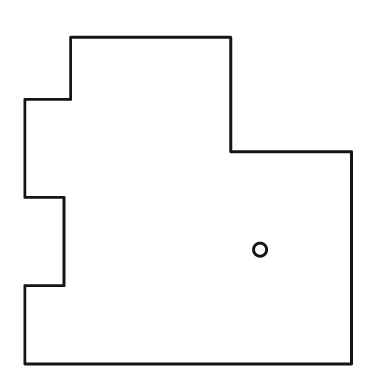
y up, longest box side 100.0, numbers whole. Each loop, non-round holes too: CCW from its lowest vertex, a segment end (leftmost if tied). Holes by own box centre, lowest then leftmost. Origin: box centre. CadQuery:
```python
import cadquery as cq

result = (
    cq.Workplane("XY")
    .moveTo(-50.0, -50.0)
    .lineTo(50.0, -50.0)
    .lineTo(50.0, 15.0)
    .lineTo(13.0, 15.0)
    .lineTo(13.0, 50.0)
    .lineTo(-36.0, 50.0)
    .lineTo(-36.0, 31.0)
    .lineTo(-50.0, 31.0)
    .lineTo(-50.0, 1.0)
    .lineTo(-38.0, 1.0)
    .lineTo(-38.0, -26.0)
    .lineTo(-50.0, -26.0)
    .close()
    .moveTo(22.0, -15.0)
    .circle(2.0)
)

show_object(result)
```